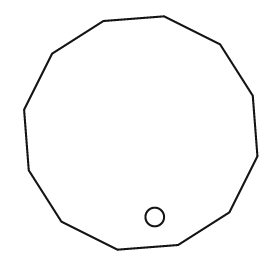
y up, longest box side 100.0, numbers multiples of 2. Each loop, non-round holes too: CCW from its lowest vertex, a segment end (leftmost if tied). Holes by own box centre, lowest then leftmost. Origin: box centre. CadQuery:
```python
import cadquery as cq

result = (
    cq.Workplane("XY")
    .moveTo(-10.0, -50.0)
    .lineTo(16.0, -48.0)
    .lineTo(38.0, -34.0)
    .lineTo(50.0, -10.0)
    .lineTo(48.0, 16.0)
    .lineTo(34.0, 38.0)
    .lineTo(10.0, 50.0)
    .lineTo(-16.0, 48.0)
    .lineTo(-38.0, 34.0)
    .lineTo(-50.0, 10.0)
    .lineTo(-48.0, -16.0)
    .lineTo(-34.0, -38.0)
    .close()
    .moveTo(6.0, -36.0)
    .circle(4.0)
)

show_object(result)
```